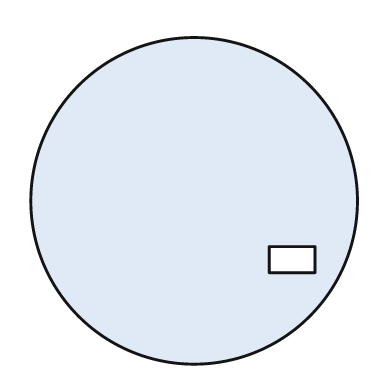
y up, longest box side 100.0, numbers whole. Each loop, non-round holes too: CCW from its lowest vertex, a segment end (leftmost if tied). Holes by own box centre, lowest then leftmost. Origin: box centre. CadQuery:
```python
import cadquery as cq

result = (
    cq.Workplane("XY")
    .moveTo(0.0, 0.0)
    .circle(50.0)
    .moveTo(23.0, -22.0)
    .lineTo(37.0, -22.0)
    .lineTo(37.0, -14.0)
    .lineTo(23.0, -14.0)
    .close()
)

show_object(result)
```